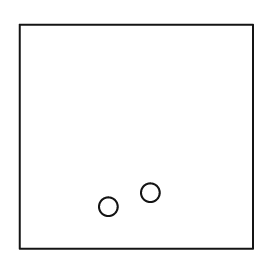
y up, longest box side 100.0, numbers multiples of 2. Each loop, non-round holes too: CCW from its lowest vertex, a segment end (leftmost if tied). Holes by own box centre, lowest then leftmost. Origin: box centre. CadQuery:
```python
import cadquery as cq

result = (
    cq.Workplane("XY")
    .moveTo(-50.0, -48.0)
    .lineTo(50.0, -48.0)
    .lineTo(50.0, 48.0)
    .lineTo(-50.0, 48.0)
    .close()
    .moveTo(-12.0, -30.0)
    .circle(4.0)
    .moveTo(6.0, -24.0)
    .circle(4.0)
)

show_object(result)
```